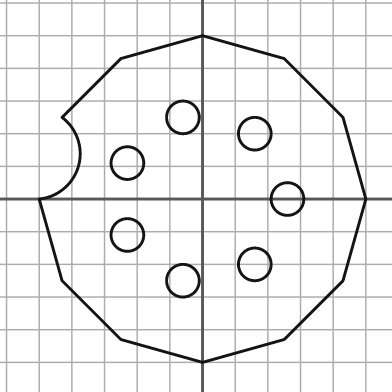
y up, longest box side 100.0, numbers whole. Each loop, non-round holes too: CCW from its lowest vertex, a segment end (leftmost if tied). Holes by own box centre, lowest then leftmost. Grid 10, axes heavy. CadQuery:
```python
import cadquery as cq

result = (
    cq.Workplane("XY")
    .moveTo(0.0, -50.0)
    .lineTo(25.0, -43.0)
    .lineTo(43.0, -25.0)
    .lineTo(50.0, 0.0)
    .lineTo(43.0, 25.0)
    .lineTo(25.0, 43.0)
    .lineTo(0.0, 50.0)
    .lineTo(-25.0, 43.0)
    .lineTo(-43.0, 25.0)
    .threePointArc((-38.0, 10.0), (-50.0, 0.0))
    .lineTo(-43.0, -25.0)
    .lineTo(-25.0, -43.0)
    .close()
    .moveTo(-6.0, -25.0)
    .circle(5.0)
    .moveTo(16.0, -20.0)
    .circle(5.0)
    .moveTo(-23.0, -11.0)
    .circle(5.0)
    .moveTo(26.0, 0.0)
    .circle(5.0)
    .moveTo(-23.0, 11.0)
    .circle(5.0)
    .moveTo(16.0, 20.0)
    .circle(5.0)
    .moveTo(-6.0, 25.0)
    .circle(5.0)
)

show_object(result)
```